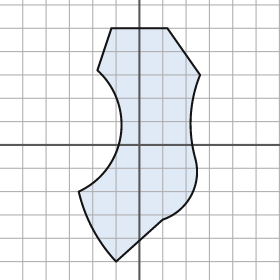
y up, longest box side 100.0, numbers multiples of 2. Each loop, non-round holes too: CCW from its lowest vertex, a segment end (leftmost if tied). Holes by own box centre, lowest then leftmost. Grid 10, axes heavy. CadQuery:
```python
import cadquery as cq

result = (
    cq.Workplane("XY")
    .moveTo(-10.0, -50.0)
    .lineTo(10.0, -32.0)
    .threePointArc((22.0, -22.0), (24.0, -6.0))
    .threePointArc((22.0, 12.0), (26.0, 30.0))
    .lineTo(12.0, 50.0)
    .lineTo(-12.0, 50.0)
    .lineTo(-18.0, 32.0)
    .threePointArc((-8.0, 4.0), (-26.0, -20.0))
    .threePointArc((-20.0, -36.0), (-10.0, -50.0))
    .close()
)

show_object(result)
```